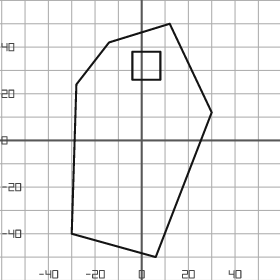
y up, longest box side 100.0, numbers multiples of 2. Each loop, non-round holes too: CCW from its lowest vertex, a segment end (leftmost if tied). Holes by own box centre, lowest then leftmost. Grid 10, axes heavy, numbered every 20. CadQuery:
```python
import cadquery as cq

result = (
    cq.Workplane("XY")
    .moveTo(6.0, -50.0)
    .lineTo(30.0, 12.0)
    .lineTo(12.0, 50.0)
    .lineTo(-14.0, 42.0)
    .lineTo(-28.0, 24.0)
    .lineTo(-30.0, -40.0)
    .close()
    .moveTo(-4.0, 26.0)
    .lineTo(8.0, 26.0)
    .lineTo(8.0, 38.0)
    .lineTo(-4.0, 38.0)
    .close()
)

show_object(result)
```